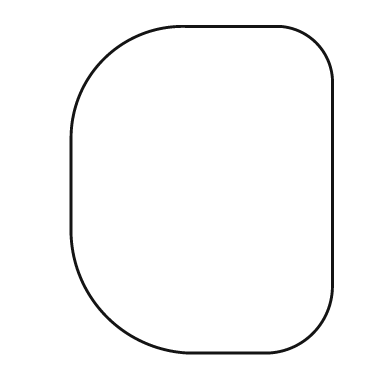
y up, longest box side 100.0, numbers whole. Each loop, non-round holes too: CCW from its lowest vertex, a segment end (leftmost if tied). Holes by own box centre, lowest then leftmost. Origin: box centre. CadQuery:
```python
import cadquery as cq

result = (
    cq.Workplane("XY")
    .moveTo(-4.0, -50.0)
    .lineTo(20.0, -50.0)
    .threePointArc((34.0, -44.0), (40.0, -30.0))
    .lineTo(40.0, 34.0)
    .threePointArc((35.0, 45.0), (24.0, 50.0))
    .lineTo(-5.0, 50.0)
    .threePointArc((-30.0, 40.0), (-40.0, 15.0))
    .lineTo(-40.0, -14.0)
    .threePointArc((-29.0, -39.0), (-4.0, -50.0))
    .close()
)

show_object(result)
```